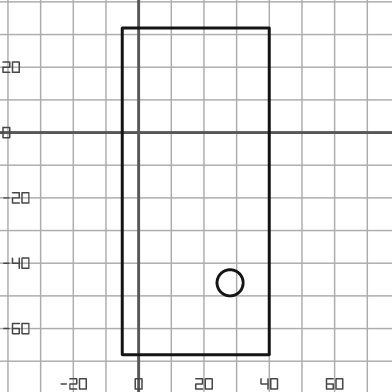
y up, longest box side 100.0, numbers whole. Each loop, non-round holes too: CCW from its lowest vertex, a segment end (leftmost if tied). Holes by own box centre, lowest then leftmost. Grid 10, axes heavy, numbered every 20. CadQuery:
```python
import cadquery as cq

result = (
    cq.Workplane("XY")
    .moveTo(-5.0, -68.0)
    .lineTo(40.0, -68.0)
    .lineTo(40.0, 32.0)
    .lineTo(-5.0, 32.0)
    .close()
    .moveTo(28.0, -46.0)
    .circle(4.0)
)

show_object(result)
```